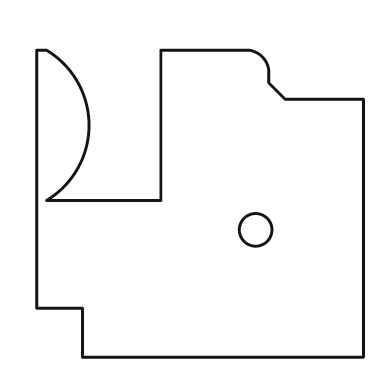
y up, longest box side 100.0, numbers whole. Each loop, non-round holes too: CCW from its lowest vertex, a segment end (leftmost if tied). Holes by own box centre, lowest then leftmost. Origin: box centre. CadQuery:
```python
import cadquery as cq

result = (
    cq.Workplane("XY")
    .moveTo(-36.0, -47.0)
    .lineTo(50.0, -47.0)
    .lineTo(50.0, 32.0)
    .lineTo(26.0, 32.0)
    .lineTo(21.0, 37.0)
    .lineTo(21.0, 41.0)
    .threePointArc((19.0, 45.0), (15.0, 47.0))
    .lineTo(-12.0, 47.0)
    .lineTo(-12.0, 1.0)
    .lineTo(-47.0, 1.0)
    .threePointArc((-34.0, 24.0), (-47.0, 47.0))
    .lineTo(-50.0, 47.0)
    .lineTo(-50.0, -32.0)
    .lineTo(-36.0, -32.0)
    .close()
    .moveTo(17.0, -8.0)
    .circle(5.0)
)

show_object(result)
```